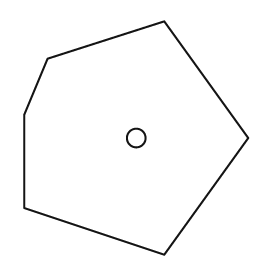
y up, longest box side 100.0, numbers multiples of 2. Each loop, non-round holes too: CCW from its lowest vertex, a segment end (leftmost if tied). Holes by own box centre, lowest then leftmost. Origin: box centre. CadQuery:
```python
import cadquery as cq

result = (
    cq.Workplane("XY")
    .moveTo(12.0, -50.0)
    .lineTo(48.0, 0.0)
    .lineTo(12.0, 50.0)
    .lineTo(-38.0, 34.0)
    .lineTo(-48.0, 10.0)
    .lineTo(-48.0, -30.0)
    .close()
    .moveTo(0.0, 0.0)
    .circle(4.0)
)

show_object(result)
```